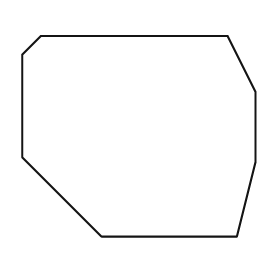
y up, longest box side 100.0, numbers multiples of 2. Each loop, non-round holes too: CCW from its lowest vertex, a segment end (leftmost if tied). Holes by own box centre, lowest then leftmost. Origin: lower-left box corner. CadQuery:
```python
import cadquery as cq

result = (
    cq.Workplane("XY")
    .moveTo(34.0, 0.0)
    .lineTo(92.0, 0.0)
    .lineTo(100.0, 32.0)
    .lineTo(100.0, 62.0)
    .lineTo(88.0, 86.0)
    .lineTo(8.0, 86.0)
    .lineTo(0.0, 78.0)
    .lineTo(0.0, 34.0)
    .close()
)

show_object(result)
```